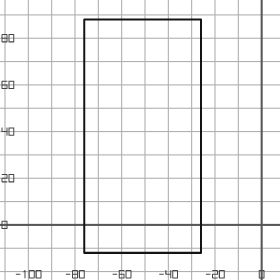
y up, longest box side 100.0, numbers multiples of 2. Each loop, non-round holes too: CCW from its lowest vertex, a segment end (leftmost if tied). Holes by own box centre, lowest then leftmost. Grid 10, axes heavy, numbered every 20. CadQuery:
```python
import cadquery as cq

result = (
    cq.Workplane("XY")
    .moveTo(-76.0, -12.0)
    .lineTo(-26.0, -12.0)
    .lineTo(-26.0, 88.0)
    .lineTo(-76.0, 88.0)
    .close()
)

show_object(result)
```